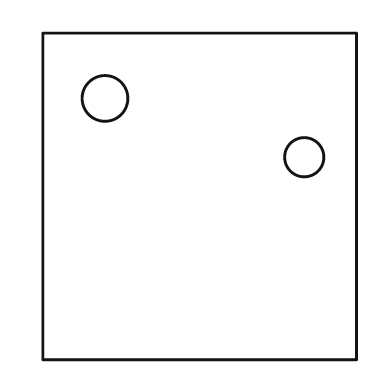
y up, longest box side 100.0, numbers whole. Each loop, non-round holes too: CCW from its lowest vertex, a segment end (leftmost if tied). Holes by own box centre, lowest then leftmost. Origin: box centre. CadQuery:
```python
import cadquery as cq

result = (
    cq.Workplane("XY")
    .moveTo(-48.0, -50.0)
    .lineTo(48.0, -50.0)
    .lineTo(48.0, 50.0)
    .lineTo(-48.0, 50.0)
    .close()
    .moveTo(32.0, 12.0)
    .circle(6.0)
    .moveTo(-29.0, 30.0)
    .circle(7.0)
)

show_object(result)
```